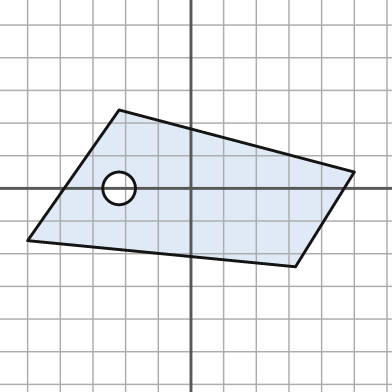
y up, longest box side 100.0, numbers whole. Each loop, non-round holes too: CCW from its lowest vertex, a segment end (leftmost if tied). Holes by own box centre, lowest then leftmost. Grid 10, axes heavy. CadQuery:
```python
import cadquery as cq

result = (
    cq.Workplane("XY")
    .moveTo(32.0, -24.0)
    .lineTo(50.0, 5.0)
    .lineTo(-22.0, 24.0)
    .lineTo(-50.0, -16.0)
    .close()
    .moveTo(-22.0, 0.0)
    .circle(5.0)
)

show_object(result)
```